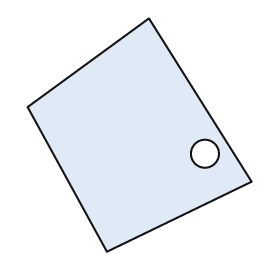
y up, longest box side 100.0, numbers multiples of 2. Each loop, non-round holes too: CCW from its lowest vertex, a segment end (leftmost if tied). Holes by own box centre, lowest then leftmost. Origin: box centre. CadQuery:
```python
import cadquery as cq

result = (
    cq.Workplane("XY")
    .moveTo(-14.0, -50.0)
    .lineTo(48.0, -20.0)
    .lineTo(4.0, 50.0)
    .lineTo(-48.0, 12.0)
    .close()
    .moveTo(28.0, -8.0)
    .circle(6.0)
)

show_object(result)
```